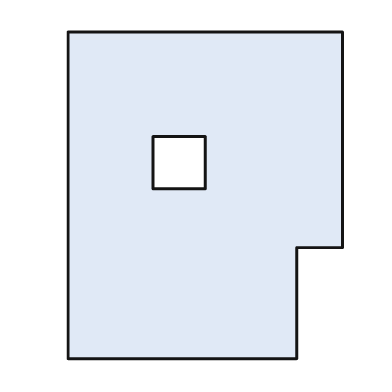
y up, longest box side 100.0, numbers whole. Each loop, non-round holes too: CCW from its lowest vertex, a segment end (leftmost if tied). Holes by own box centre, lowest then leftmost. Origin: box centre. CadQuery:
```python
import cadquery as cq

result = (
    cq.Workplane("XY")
    .moveTo(-42.0, -50.0)
    .lineTo(28.0, -50.0)
    .lineTo(28.0, -16.0)
    .lineTo(42.0, -16.0)
    .lineTo(42.0, 50.0)
    .lineTo(-42.0, 50.0)
    .close()
    .moveTo(-16.0, 2.0)
    .lineTo(0.0, 2.0)
    .lineTo(0.0, 18.0)
    .lineTo(-16.0, 18.0)
    .close()
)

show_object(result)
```